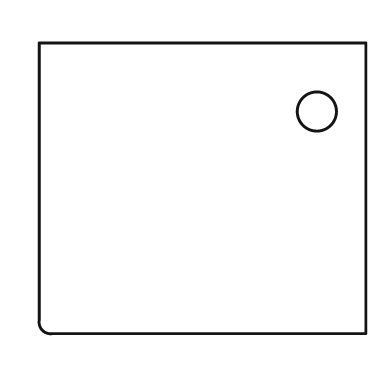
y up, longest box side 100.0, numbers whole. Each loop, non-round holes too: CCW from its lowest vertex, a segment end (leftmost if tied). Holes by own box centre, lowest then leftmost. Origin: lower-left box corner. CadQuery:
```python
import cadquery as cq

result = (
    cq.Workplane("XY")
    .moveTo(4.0, 0.0)
    .lineTo(100.0, 0.0)
    .lineTo(100.0, 89.0)
    .lineTo(0.0, 89.0)
    .lineTo(0.0, 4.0)
    .threePointArc((1.0, 1.0), (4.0, 0.0))
    .close()
    .moveTo(85.0, 68.0)
    .circle(6.0)
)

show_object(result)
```